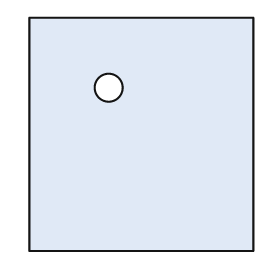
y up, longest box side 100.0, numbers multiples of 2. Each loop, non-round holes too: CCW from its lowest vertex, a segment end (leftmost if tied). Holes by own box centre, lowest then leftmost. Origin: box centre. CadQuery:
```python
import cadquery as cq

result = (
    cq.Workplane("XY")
    .moveTo(-48.0, -50.0)
    .lineTo(48.0, -50.0)
    .lineTo(48.0, 50.0)
    .lineTo(-48.0, 50.0)
    .close()
    .moveTo(-14.0, 20.0)
    .circle(6.0)
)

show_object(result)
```